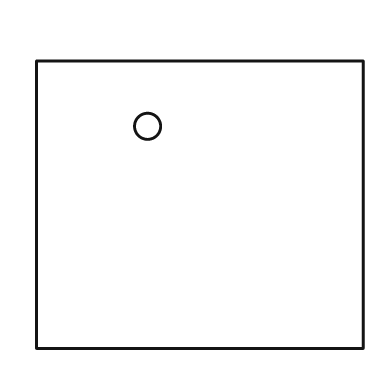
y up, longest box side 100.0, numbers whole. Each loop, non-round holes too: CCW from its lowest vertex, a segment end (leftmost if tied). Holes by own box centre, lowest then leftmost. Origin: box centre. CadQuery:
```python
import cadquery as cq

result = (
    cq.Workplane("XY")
    .moveTo(-50.0, -44.0)
    .lineTo(50.0, -44.0)
    .lineTo(50.0, 44.0)
    .lineTo(-50.0, 44.0)
    .close()
    .moveTo(-16.0, 24.0)
    .circle(4.0)
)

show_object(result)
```